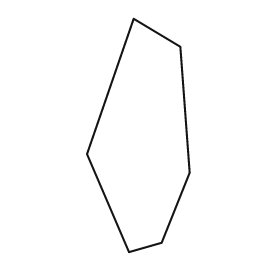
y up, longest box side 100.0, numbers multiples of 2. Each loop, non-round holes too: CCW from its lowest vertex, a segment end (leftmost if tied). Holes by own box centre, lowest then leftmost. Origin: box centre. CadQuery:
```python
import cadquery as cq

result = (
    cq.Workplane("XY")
    .moveTo(-4.0, -50.0)
    .lineTo(10.0, -46.0)
    .lineTo(22.0, -16.0)
    .lineTo(18.0, 38.0)
    .lineTo(-2.0, 50.0)
    .lineTo(-22.0, -8.0)
    .close()
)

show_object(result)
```